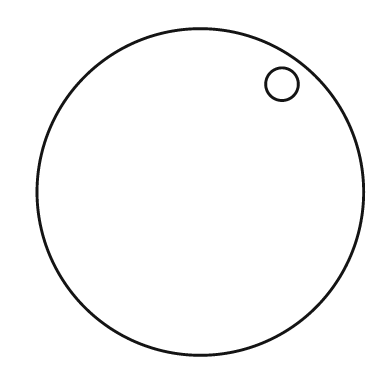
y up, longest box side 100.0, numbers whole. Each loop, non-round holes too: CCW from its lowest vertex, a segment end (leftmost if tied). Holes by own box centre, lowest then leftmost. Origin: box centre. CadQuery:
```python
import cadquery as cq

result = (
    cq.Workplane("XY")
    .moveTo(0.0, 0.0)
    .circle(50.0)
    .moveTo(25.0, 33.0)
    .circle(5.0)
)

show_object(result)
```